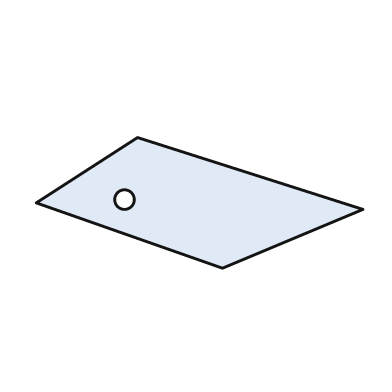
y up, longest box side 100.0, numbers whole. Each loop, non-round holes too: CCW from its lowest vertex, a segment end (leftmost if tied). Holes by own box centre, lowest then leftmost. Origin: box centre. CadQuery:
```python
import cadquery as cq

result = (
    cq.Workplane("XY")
    .moveTo(7.0, -20.0)
    .lineTo(50.0, -2.0)
    .lineTo(-19.0, 20.0)
    .lineTo(-50.0, 0.0)
    .close()
    .moveTo(-23.0, 1.0)
    .circle(3.0)
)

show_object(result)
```